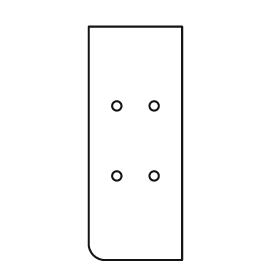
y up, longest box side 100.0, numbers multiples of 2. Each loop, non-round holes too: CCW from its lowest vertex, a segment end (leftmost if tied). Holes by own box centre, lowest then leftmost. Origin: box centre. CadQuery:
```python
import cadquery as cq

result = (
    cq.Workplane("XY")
    .moveTo(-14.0, -50.0)
    .lineTo(20.0, -50.0)
    .lineTo(20.0, 50.0)
    .lineTo(-20.0, 50.0)
    .lineTo(-20.0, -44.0)
    .threePointArc((-18.0, -48.0), (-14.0, -50.0))
    .close()
    .moveTo(-8.0, -14.0)
    .circle(2.0)
    .moveTo(8.0, -14.0)
    .circle(2.0)
    .moveTo(-8.0, 16.0)
    .circle(2.0)
    .moveTo(8.0, 16.0)
    .circle(2.0)
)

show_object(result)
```